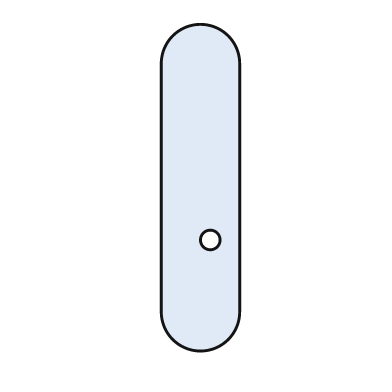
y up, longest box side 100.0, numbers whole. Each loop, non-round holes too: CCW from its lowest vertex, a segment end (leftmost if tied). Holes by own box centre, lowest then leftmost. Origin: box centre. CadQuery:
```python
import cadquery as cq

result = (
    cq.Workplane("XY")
    .moveTo(-12.0, -38.0)
    .threePointArc((0.0, -50.0), (12.0, -38.0))
    .lineTo(12.0, 38.0)
    .threePointArc((0.0, 50.0), (-12.0, 38.0))
    .close()
    .moveTo(3.0, -16.0)
    .circle(3.0)
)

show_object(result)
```